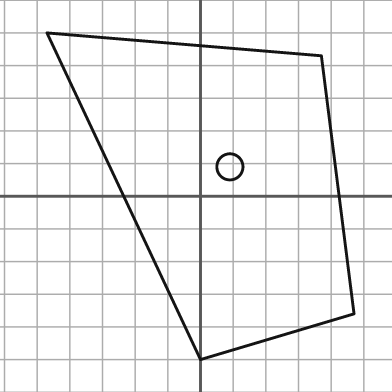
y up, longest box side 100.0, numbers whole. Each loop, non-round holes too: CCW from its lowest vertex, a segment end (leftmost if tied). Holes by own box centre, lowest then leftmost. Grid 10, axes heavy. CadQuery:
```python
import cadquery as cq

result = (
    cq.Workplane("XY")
    .moveTo(0.0, -50.0)
    .lineTo(47.0, -36.0)
    .lineTo(37.0, 43.0)
    .lineTo(-47.0, 50.0)
    .close()
    .moveTo(9.0, 9.0)
    .circle(4.0)
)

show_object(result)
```